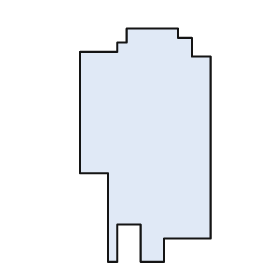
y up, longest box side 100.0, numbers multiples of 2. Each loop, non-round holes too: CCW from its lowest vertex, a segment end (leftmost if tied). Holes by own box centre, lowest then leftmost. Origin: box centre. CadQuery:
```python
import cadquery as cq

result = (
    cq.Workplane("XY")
    .moveTo(-16.0, -50.0)
    .lineTo(-12.0, -50.0)
    .lineTo(-12.0, -34.0)
    .lineTo(-2.0, -34.0)
    .lineTo(-2.0, -50.0)
    .lineTo(8.0, -50.0)
    .lineTo(8.0, -40.0)
    .lineTo(28.0, -40.0)
    .lineTo(28.0, 38.0)
    .lineTo(20.0, 38.0)
    .lineTo(20.0, 46.0)
    .lineTo(14.0, 46.0)
    .lineTo(14.0, 50.0)
    .lineTo(-8.0, 50.0)
    .lineTo(-8.0, 44.0)
    .lineTo(-12.0, 44.0)
    .lineTo(-12.0, 40.0)
    .lineTo(-28.0, 40.0)
    .lineTo(-28.0, -12.0)
    .lineTo(-16.0, -12.0)
    .close()
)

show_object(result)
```